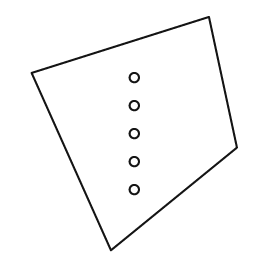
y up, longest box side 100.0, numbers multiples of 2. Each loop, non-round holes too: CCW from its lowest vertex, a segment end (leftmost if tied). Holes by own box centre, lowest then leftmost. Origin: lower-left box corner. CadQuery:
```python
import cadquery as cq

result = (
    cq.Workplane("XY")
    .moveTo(34.0, 0.0)
    .lineTo(88.0, 44.0)
    .lineTo(76.0, 100.0)
    .lineTo(0.0, 76.0)
    .close()
    .moveTo(44.0, 26.0)
    .circle(2.0)
    .moveTo(44.0, 38.0)
    .circle(2.0)
    .moveTo(44.0, 50.0)
    .circle(2.0)
    .moveTo(44.0, 62.0)
    .circle(2.0)
    .moveTo(44.0, 74.0)
    .circle(2.0)
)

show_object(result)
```